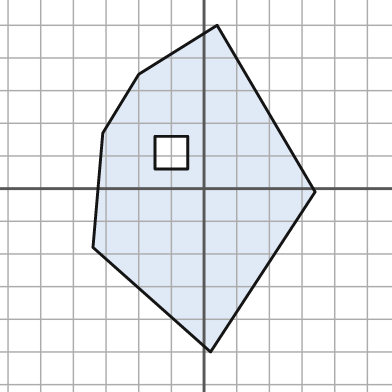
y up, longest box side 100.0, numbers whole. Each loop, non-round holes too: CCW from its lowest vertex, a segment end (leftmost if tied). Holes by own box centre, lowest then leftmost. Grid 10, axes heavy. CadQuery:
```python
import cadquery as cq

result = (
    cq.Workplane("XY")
    .moveTo(2.0, -50.0)
    .lineTo(34.0, -1.0)
    .lineTo(4.0, 50.0)
    .lineTo(-20.0, 35.0)
    .lineTo(-31.0, 17.0)
    .lineTo(-34.0, -18.0)
    .close()
    .moveTo(-15.0, 6.0)
    .lineTo(-5.0, 6.0)
    .lineTo(-5.0, 16.0)
    .lineTo(-15.0, 16.0)
    .close()
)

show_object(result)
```